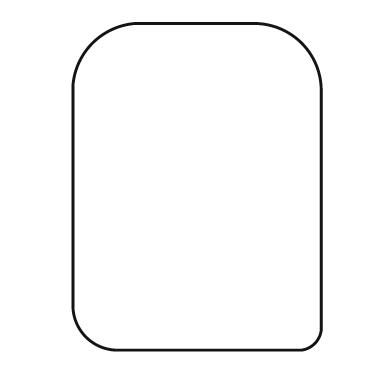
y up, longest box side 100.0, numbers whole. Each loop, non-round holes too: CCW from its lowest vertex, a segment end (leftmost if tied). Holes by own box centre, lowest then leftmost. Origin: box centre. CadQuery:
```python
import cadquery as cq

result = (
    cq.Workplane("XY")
    .moveTo(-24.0, -50.0)
    .lineTo(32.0, -50.0)
    .threePointArc((36.0, -48.0), (38.0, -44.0))
    .lineTo(38.0, 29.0)
    .threePointArc((32.0, 44.0), (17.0, 50.0))
    .lineTo(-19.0, 50.0)
    .threePointArc((-32.0, 44.0), (-38.0, 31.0))
    .lineTo(-38.0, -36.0)
    .threePointArc((-34.0, -46.0), (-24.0, -50.0))
    .close()
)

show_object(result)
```